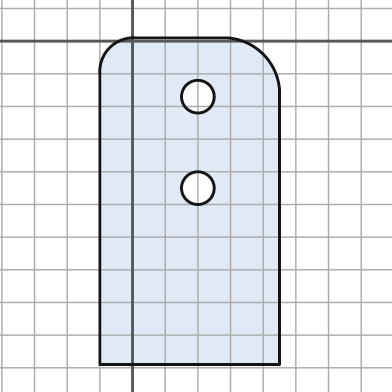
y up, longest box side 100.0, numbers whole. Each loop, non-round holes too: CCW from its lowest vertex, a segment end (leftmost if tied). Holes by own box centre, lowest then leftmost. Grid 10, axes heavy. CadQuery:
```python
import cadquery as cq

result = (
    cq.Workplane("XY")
    .moveTo(-10.0, -99.0)
    .lineTo(45.0, -99.0)
    .lineTo(45.0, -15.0)
    .threePointArc((40.0, -4.0), (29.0, 1.0))
    .lineTo(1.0, 1.0)
    .threePointArc((-7.0, -2.0), (-10.0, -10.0))
    .close()
    .moveTo(20.0, -45.0)
    .circle(5.0)
    .moveTo(20.0, -17.0)
    .circle(5.0)
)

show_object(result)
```